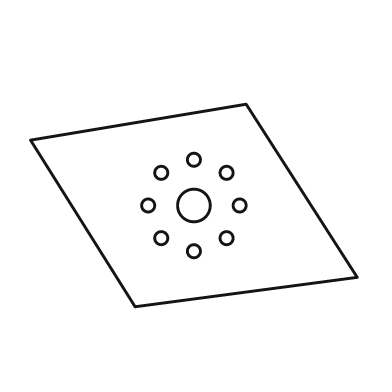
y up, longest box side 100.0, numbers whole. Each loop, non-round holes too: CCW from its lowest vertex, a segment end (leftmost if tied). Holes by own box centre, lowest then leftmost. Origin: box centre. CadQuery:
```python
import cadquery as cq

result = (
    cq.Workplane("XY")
    .moveTo(-18.0, -31.0)
    .lineTo(50.0, -22.0)
    .lineTo(16.0, 31.0)
    .lineTo(-50.0, 20.0)
    .close()
    .moveTo(0.0, -14.0)
    .circle(2.0)
    .moveTo(-10.0, -10.0)
    .circle(2.0)
    .moveTo(10.0, -10.0)
    .circle(2.0)
    .moveTo(-14.0, 0.0)
    .circle(2.0)
    .moveTo(0.0, 0.0)
    .circle(5.0)
    .moveTo(14.0, 0.0)
    .circle(2.0)
    .moveTo(-10.0, 10.0)
    .circle(2.0)
    .moveTo(10.0, 10.0)
    .circle(2.0)
    .moveTo(0.0, 14.0)
    .circle(2.0)
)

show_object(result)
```